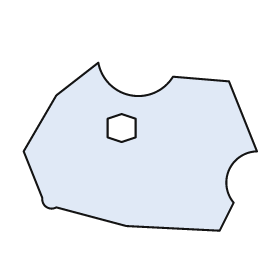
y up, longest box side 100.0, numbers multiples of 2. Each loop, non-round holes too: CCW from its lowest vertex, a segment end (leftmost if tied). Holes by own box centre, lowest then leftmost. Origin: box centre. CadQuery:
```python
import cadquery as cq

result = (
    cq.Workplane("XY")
    .moveTo(34.0, -36.0)
    .lineTo(40.0, -24.0)
    .threePointArc((38.0, -10.0), (50.0, -2.0))
    .lineTo(38.0, 28.0)
    .lineTo(14.0, 30.0)
    .threePointArc((-4.0, 22.0), (-18.0, 36.0))
    .lineTo(-36.0, 22.0)
    .lineTo(-50.0, -2.0)
    .lineTo(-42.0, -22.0)
    .threePointArc((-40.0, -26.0), (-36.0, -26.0))
    .lineTo(-6.0, -34.0)
    .close()
    .moveTo(-8.0, 2.0)
    .lineTo(-2.0, 4.0)
    .lineTo(-2.0, 12.0)
    .lineTo(-8.0, 14.0)
    .lineTo(-14.0, 12.0)
    .lineTo(-14.0, 4.0)
    .close()
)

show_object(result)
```